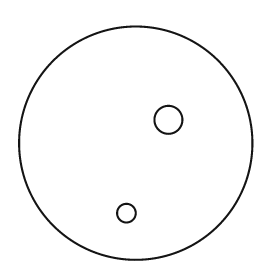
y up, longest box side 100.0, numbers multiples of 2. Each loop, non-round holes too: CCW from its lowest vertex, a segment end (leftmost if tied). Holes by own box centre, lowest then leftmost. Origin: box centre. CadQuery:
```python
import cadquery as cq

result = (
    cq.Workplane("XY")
    .moveTo(0.0, 0.0)
    .circle(50.0)
    .moveTo(-4.0, -30.0)
    .circle(4.0)
    .moveTo(14.0, 10.0)
    .circle(6.0)
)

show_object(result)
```